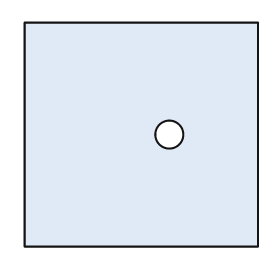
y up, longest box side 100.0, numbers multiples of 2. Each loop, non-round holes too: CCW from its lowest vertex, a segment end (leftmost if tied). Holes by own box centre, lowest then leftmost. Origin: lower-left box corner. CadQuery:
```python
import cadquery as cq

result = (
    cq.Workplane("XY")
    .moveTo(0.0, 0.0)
    .lineTo(100.0, 0.0)
    .lineTo(100.0, 96.0)
    .lineTo(0.0, 96.0)
    .close()
    .moveTo(62.0, 48.0)
    .circle(6.0)
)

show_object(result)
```